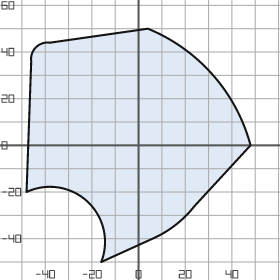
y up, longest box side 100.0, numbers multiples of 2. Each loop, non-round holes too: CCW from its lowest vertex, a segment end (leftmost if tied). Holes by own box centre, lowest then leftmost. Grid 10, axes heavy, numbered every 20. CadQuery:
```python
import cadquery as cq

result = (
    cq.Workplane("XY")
    .moveTo(-16.0, -50.0)
    .lineTo(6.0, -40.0)
    .threePointArc((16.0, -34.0), (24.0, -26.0))
    .lineTo(48.0, 0.0)
    .threePointArc((32.0, 30.0), (4.0, 50.0))
    .lineTo(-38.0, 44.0)
    .threePointArc((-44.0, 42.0), (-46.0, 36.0))
    .lineTo(-48.0, -20.0)
    .threePointArc((-22.0, -24.0), (-16.0, -50.0))
    .close()
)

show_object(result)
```